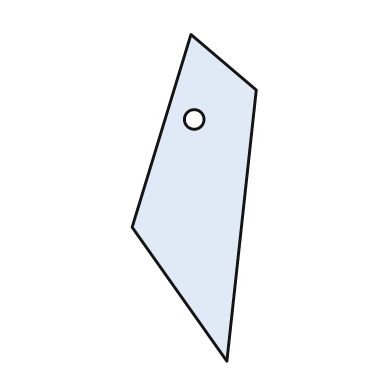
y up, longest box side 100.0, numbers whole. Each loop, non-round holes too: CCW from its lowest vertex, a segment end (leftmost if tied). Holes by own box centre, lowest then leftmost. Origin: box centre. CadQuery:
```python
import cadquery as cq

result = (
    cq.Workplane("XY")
    .moveTo(10.0, -50.0)
    .lineTo(19.0, 33.0)
    .lineTo(-1.0, 50.0)
    .lineTo(-19.0, -9.0)
    .close()
    .moveTo(0.0, 24.0)
    .circle(3.0)
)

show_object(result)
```